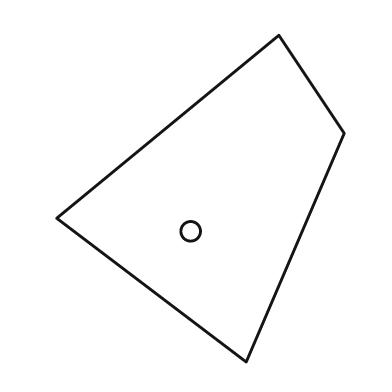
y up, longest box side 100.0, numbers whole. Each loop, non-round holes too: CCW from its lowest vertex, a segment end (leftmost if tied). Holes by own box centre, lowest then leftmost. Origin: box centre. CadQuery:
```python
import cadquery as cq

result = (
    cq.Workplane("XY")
    .moveTo(14.0, -50.0)
    .lineTo(44.0, 20.0)
    .lineTo(24.0, 50.0)
    .lineTo(-44.0, -6.0)
    .close()
    .moveTo(-3.0, -10.0)
    .circle(3.0)
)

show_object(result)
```